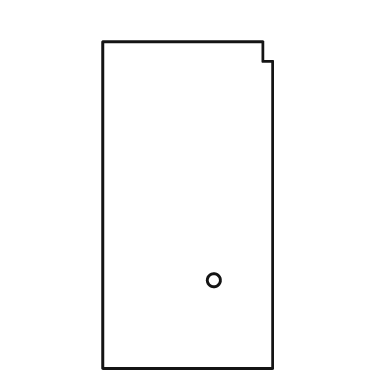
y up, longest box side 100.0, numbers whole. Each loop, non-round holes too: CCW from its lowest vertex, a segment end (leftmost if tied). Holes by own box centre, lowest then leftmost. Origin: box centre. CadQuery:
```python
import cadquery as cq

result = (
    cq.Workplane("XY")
    .moveTo(-26.0, -50.0)
    .lineTo(26.0, -50.0)
    .lineTo(26.0, 44.0)
    .lineTo(23.0, 44.0)
    .lineTo(23.0, 50.0)
    .lineTo(-26.0, 50.0)
    .close()
    .moveTo(8.0, -23.0)
    .circle(2.0)
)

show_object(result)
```